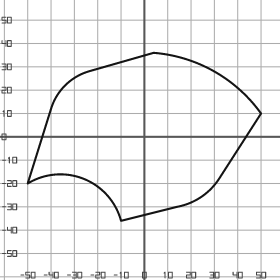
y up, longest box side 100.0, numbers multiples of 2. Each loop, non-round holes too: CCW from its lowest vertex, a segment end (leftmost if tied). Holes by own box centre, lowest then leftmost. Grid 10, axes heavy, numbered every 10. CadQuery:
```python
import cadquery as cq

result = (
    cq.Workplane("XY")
    .moveTo(-10.0, -36.0)
    .lineTo(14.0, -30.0)
    .threePointArc((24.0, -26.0), (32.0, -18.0))
    .lineTo(50.0, 10.0)
    .threePointArc((30.0, 28.0), (4.0, 36.0))
    .lineTo(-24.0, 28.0)
    .threePointArc((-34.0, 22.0), (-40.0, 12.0))
    .lineTo(-50.0, -20.0)
    .threePointArc((-26.0, -18.0), (-10.0, -36.0))
    .close()
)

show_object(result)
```